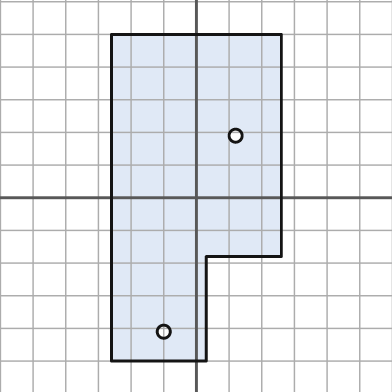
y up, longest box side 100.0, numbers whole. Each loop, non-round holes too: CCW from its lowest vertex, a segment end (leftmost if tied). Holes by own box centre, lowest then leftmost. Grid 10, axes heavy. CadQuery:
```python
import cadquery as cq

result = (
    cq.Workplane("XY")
    .moveTo(-26.0, -50.0)
    .lineTo(3.0, -50.0)
    .lineTo(3.0, -18.0)
    .lineTo(26.0, -18.0)
    .lineTo(26.0, 50.0)
    .lineTo(-26.0, 50.0)
    .close()
    .moveTo(-10.0, -41.0)
    .circle(2.0)
    .moveTo(12.0, 19.0)
    .circle(2.0)
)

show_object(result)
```